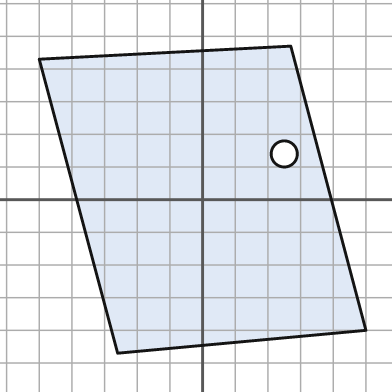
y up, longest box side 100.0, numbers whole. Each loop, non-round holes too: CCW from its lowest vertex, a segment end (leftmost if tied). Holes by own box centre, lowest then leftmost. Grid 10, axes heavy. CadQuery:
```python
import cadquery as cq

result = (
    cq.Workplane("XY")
    .moveTo(-26.0, -47.0)
    .lineTo(50.0, -40.0)
    .lineTo(27.0, 47.0)
    .lineTo(-50.0, 43.0)
    .close()
    .moveTo(25.0, 14.0)
    .circle(4.0)
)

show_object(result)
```